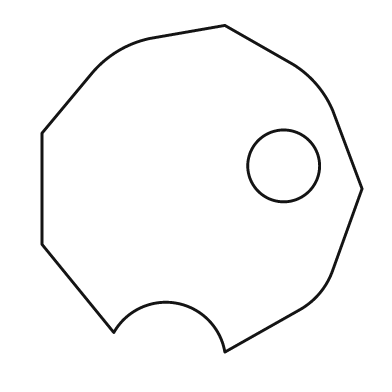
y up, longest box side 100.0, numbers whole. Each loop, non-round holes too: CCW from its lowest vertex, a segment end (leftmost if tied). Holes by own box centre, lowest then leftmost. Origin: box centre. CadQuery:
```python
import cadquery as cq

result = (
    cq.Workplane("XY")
    .moveTo(7.0, -50.0)
    .lineTo(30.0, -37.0)
    .threePointArc((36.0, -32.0), (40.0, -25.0))
    .lineTo(49.0, 0.0)
    .lineTo(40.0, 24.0)
    .threePointArc((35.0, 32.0), (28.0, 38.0))
    .lineTo(7.0, 50.0)
    .lineTo(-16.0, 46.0)
    .threePointArc((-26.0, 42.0), (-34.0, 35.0))
    .lineTo(-49.0, 17.0)
    .lineTo(-49.0, -17.0)
    .lineTo(-27.0, -44.0)
    .threePointArc((-8.0, -35.0), (7.0, -50.0))
    .close()
    .moveTo(25.0, 7.0)
    .circle(11.0)
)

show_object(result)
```